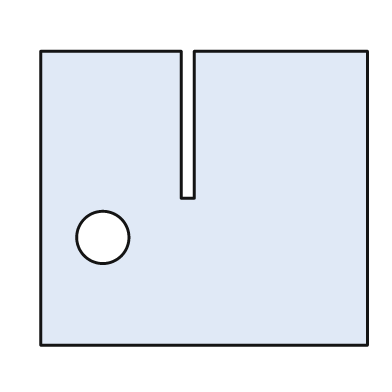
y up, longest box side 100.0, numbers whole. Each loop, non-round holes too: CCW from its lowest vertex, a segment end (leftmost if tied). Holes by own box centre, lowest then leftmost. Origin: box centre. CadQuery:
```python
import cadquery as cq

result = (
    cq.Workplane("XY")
    .moveTo(-50.0, -45.0)
    .lineTo(50.0, -45.0)
    .lineTo(50.0, 45.0)
    .lineTo(-3.0, 45.0)
    .lineTo(-3.0, 0.0)
    .lineTo(-7.0, 0.0)
    .lineTo(-7.0, 45.0)
    .lineTo(-50.0, 45.0)
    .close()
    .moveTo(-31.0, -12.0)
    .circle(8.0)
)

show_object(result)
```